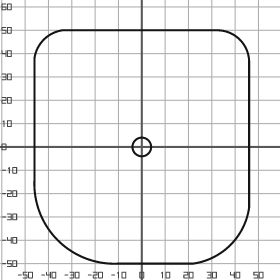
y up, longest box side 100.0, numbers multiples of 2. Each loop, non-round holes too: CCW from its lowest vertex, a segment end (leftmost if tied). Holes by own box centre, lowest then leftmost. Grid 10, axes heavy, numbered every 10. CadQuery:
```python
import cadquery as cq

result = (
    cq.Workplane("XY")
    .moveTo(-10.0, -50.0)
    .lineTo(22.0, -50.0)
    .threePointArc((38.0, -42.0), (46.0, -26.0))
    .lineTo(46.0, 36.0)
    .threePointArc((42.0, 46.0), (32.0, 50.0))
    .lineTo(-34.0, 50.0)
    .threePointArc((-42.0, 46.0), (-46.0, 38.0))
    .lineTo(-46.0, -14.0)
    .threePointArc((-36.0, -40.0), (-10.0, -50.0))
    .close()
    .moveTo(0.0, 0.0)
    .circle(4.0)
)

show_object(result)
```